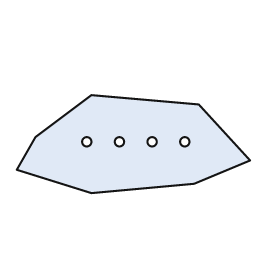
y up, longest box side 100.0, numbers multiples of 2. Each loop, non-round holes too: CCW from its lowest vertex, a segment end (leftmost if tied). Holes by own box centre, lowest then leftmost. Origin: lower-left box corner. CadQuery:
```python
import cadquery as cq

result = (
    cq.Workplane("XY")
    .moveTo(32.0, 0.0)
    .lineTo(76.0, 4.0)
    .lineTo(100.0, 14.0)
    .lineTo(78.0, 38.0)
    .lineTo(32.0, 42.0)
    .lineTo(8.0, 24.0)
    .lineTo(0.0, 10.0)
    .close()
    .moveTo(30.0, 22.0)
    .circle(2.0)
    .moveTo(44.0, 22.0)
    .circle(2.0)
    .moveTo(58.0, 22.0)
    .circle(2.0)
    .moveTo(72.0, 22.0)
    .circle(2.0)
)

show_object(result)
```